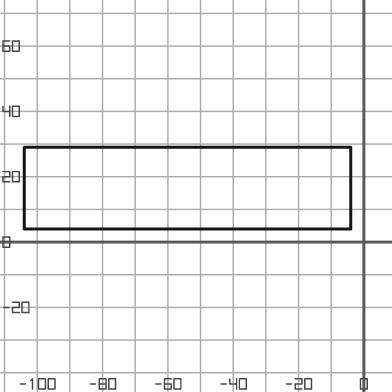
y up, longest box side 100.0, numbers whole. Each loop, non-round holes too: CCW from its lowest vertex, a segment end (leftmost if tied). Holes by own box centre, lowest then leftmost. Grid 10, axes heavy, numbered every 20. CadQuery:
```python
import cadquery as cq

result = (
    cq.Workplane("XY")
    .moveTo(-104.0, 4.0)
    .lineTo(-4.0, 4.0)
    .lineTo(-4.0, 29.0)
    .lineTo(-104.0, 29.0)
    .close()
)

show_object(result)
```